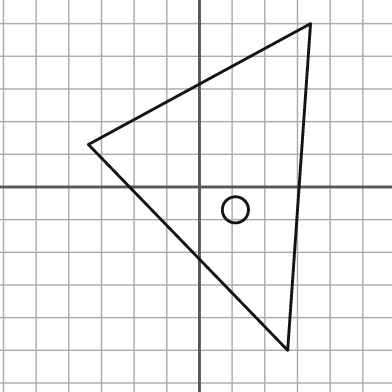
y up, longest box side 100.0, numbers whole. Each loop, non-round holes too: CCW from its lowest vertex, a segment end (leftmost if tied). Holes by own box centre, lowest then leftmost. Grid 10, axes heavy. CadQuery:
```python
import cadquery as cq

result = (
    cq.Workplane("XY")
    .moveTo(27.0, -50.0)
    .lineTo(34.0, 50.0)
    .lineTo(-34.0, 13.0)
    .close()
    .moveTo(11.0, -7.0)
    .circle(4.0)
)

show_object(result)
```